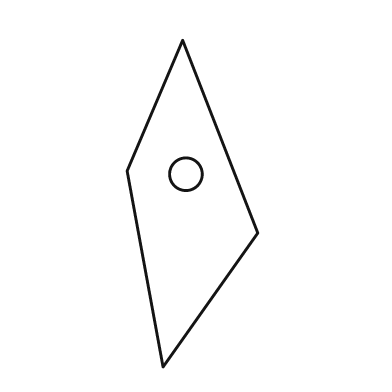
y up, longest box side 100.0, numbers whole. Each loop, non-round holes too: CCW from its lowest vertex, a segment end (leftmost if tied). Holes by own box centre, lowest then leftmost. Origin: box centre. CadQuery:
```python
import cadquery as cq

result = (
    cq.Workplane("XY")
    .moveTo(-9.0, -50.0)
    .lineTo(20.0, -9.0)
    .lineTo(-3.0, 50.0)
    .lineTo(-20.0, 10.0)
    .close()
    .moveTo(-2.0, 9.0)
    .circle(5.0)
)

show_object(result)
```